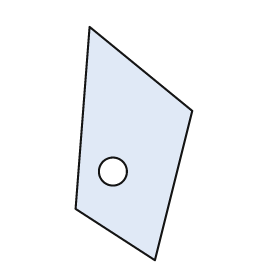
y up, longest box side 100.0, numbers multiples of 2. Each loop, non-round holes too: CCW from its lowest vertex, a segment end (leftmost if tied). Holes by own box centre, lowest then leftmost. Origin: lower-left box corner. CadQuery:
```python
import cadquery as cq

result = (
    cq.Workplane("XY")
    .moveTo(34.0, 0.0)
    .lineTo(50.0, 64.0)
    .lineTo(6.0, 100.0)
    .lineTo(0.0, 22.0)
    .close()
    .moveTo(16.0, 38.0)
    .circle(6.0)
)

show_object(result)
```